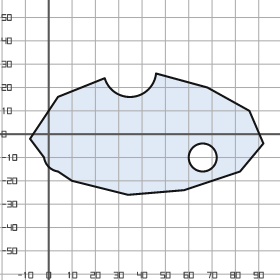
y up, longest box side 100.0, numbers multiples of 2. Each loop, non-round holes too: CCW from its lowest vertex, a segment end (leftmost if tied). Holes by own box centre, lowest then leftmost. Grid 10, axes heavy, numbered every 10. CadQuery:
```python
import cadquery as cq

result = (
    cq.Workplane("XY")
    .moveTo(34.0, -26.0)
    .lineTo(58.0, -24.0)
    .lineTo(82.0, -16.0)
    .lineTo(92.0, -4.0)
    .lineTo(86.0, 10.0)
    .lineTo(68.0, 20.0)
    .lineTo(46.0, 26.0)
    .threePointArc((36.0, 16.0), (24.0, 24.0))
    .lineTo(4.0, 16.0)
    .lineTo(-8.0, -2.0)
    .lineTo(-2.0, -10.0)
    .threePointArc((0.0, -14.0), (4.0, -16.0))
    .lineTo(10.0, -20.0)
    .close()
    .moveTo(66.0, -10.0)
    .circle(6.0)
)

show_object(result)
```